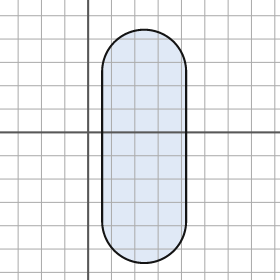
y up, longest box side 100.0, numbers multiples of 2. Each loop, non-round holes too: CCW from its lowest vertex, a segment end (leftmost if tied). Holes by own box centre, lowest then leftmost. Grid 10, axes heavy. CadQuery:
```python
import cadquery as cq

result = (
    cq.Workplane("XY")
    .moveTo(6.0, -38.0)
    .threePointArc((24.0, -56.0), (42.0, -38.0))
    .lineTo(42.0, 26.0)
    .threePointArc((24.0, 44.0), (6.0, 26.0))
    .close()
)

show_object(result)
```